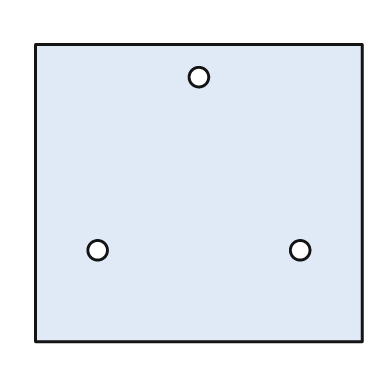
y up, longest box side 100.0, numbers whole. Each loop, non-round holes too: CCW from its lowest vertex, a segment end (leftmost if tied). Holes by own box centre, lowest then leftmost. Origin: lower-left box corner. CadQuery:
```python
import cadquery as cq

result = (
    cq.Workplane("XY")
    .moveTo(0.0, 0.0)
    .lineTo(100.0, 0.0)
    .lineTo(100.0, 91.0)
    .lineTo(0.0, 91.0)
    .close()
    .moveTo(19.0, 28.0)
    .circle(3.0)
    .moveTo(81.0, 28.0)
    .circle(3.0)
    .moveTo(50.0, 81.0)
    .circle(3.0)
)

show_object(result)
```